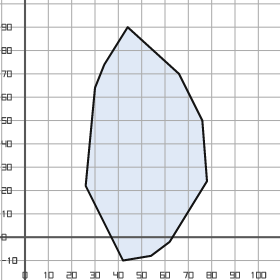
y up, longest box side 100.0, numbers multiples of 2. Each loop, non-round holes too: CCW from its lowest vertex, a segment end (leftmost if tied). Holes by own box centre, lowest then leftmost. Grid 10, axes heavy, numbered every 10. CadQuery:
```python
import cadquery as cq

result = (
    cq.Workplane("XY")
    .moveTo(42.0, -10.0)
    .lineTo(54.0, -8.0)
    .lineTo(62.0, -2.0)
    .lineTo(78.0, 24.0)
    .lineTo(76.0, 50.0)
    .lineTo(66.0, 70.0)
    .lineTo(44.0, 90.0)
    .lineTo(34.0, 74.0)
    .lineTo(30.0, 64.0)
    .lineTo(26.0, 22.0)
    .close()
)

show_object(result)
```